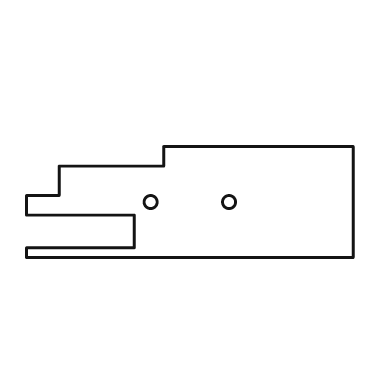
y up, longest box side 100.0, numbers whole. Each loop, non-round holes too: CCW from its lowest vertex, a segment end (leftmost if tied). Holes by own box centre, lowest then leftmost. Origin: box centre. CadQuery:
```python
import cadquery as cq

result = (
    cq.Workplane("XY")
    .moveTo(-50.0, -17.0)
    .lineTo(50.0, -17.0)
    .lineTo(50.0, 17.0)
    .lineTo(-8.0, 17.0)
    .lineTo(-8.0, 11.0)
    .lineTo(-40.0, 11.0)
    .lineTo(-40.0, 2.0)
    .lineTo(-50.0, 2.0)
    .lineTo(-50.0, -4.0)
    .lineTo(-17.0, -4.0)
    .lineTo(-17.0, -14.0)
    .lineTo(-50.0, -14.0)
    .close()
    .moveTo(-12.0, 0.0)
    .circle(2.0)
    .moveTo(12.0, 0.0)
    .circle(2.0)
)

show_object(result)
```